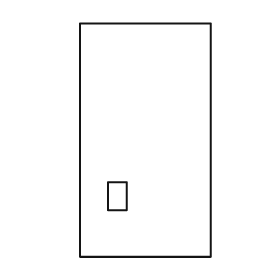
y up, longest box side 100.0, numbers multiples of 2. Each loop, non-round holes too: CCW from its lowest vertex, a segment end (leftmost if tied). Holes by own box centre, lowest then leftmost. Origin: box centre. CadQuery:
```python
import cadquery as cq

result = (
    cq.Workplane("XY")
    .moveTo(-28.0, -50.0)
    .lineTo(28.0, -50.0)
    .lineTo(28.0, 50.0)
    .lineTo(-28.0, 50.0)
    .close()
    .moveTo(-16.0, -30.0)
    .lineTo(-8.0, -30.0)
    .lineTo(-8.0, -18.0)
    .lineTo(-16.0, -18.0)
    .close()
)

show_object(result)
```